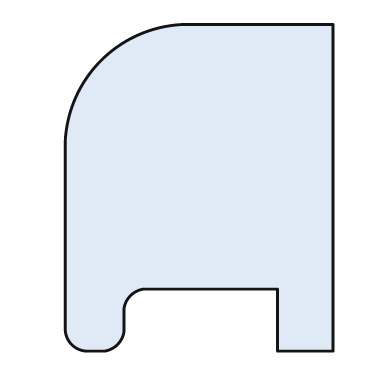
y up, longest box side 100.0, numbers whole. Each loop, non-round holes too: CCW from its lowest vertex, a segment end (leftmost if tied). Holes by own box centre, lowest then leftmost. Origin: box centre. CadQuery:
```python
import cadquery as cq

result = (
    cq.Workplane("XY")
    .moveTo(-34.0, -50.0)
    .lineTo(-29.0, -50.0)
    .threePointArc((-25.0, -48.0), (-23.0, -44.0))
    .lineTo(-23.0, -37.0)
    .threePointArc((-21.0, -33.0), (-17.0, -31.0))
    .lineTo(24.0, -31.0)
    .lineTo(24.0, -50.0)
    .lineTo(41.0, -50.0)
    .lineTo(41.0, 50.0)
    .lineTo(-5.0, 50.0)
    .threePointArc((-30.0, 39.0), (-41.0, 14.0))
    .lineTo(-41.0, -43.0)
    .threePointArc((-39.0, -48.0), (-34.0, -50.0))
    .close()
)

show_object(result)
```